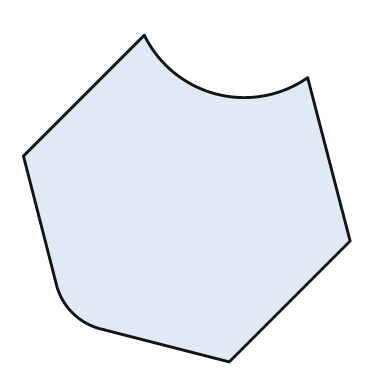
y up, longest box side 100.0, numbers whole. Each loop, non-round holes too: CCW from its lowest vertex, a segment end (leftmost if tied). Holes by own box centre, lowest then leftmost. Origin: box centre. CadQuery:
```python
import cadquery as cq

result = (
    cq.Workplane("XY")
    .moveTo(13.0, -50.0)
    .lineTo(50.0, -13.0)
    .lineTo(37.0, 37.0)
    .threePointArc((9.0, 32.0), (-13.0, 50.0))
    .lineTo(-50.0, 13.0)
    .lineTo(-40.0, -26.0)
    .threePointArc((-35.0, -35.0), (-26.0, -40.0))
    .close()
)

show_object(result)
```